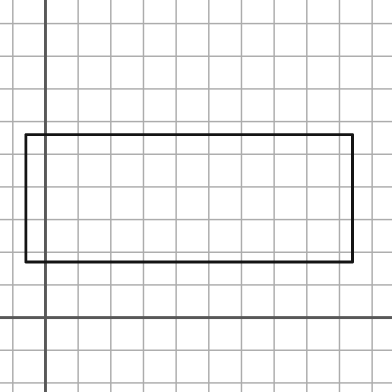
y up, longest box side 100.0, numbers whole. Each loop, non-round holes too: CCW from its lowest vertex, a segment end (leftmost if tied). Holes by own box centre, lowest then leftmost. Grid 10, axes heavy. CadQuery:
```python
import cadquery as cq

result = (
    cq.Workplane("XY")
    .moveTo(-6.0, 17.0)
    .lineTo(94.0, 17.0)
    .lineTo(94.0, 56.0)
    .lineTo(-6.0, 56.0)
    .close()
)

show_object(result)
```